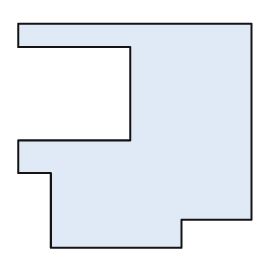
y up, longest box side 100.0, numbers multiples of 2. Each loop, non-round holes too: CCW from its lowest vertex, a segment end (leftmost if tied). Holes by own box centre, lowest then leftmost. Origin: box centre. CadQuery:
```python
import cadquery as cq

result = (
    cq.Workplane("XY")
    .moveTo(-36.0, -48.0)
    .lineTo(20.0, -48.0)
    .lineTo(20.0, -36.0)
    .lineTo(50.0, -36.0)
    .lineTo(50.0, 48.0)
    .lineTo(-50.0, 48.0)
    .lineTo(-50.0, 38.0)
    .lineTo(-2.0, 38.0)
    .lineTo(-2.0, -2.0)
    .lineTo(-50.0, -2.0)
    .lineTo(-50.0, -16.0)
    .lineTo(-36.0, -16.0)
    .close()
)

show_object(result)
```